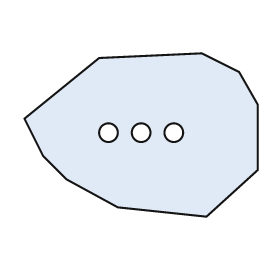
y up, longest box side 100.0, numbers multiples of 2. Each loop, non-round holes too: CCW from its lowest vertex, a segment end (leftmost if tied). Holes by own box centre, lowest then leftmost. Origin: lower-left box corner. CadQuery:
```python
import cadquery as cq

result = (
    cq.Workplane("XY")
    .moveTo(78.0, 0.0)
    .lineTo(100.0, 20.0)
    .lineTo(100.0, 48.0)
    .lineTo(92.0, 62.0)
    .lineTo(76.0, 70.0)
    .lineTo(32.0, 68.0)
    .lineTo(0.0, 42.0)
    .lineTo(8.0, 26.0)
    .lineTo(18.0, 16.0)
    .lineTo(40.0, 4.0)
    .close()
    .moveTo(36.0, 36.0)
    .circle(4.0)
    .moveTo(50.0, 36.0)
    .circle(4.0)
    .moveTo(64.0, 36.0)
    .circle(4.0)
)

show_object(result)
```